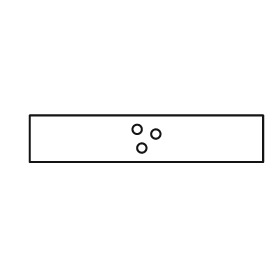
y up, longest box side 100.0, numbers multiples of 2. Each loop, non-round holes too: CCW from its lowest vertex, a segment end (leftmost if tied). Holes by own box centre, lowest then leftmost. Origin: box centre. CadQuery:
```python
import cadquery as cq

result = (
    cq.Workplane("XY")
    .moveTo(-50.0, -10.0)
    .lineTo(50.0, -10.0)
    .lineTo(50.0, 10.0)
    .lineTo(-50.0, 10.0)
    .close()
    .moveTo(-2.0, -4.0)
    .circle(2.0)
    .moveTo(4.0, 2.0)
    .circle(2.0)
    .moveTo(-4.0, 4.0)
    .circle(2.0)
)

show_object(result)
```